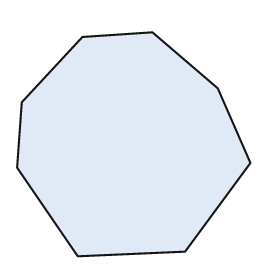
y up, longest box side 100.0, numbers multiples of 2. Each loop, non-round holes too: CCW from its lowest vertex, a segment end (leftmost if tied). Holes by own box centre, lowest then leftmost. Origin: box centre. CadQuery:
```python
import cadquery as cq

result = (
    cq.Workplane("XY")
    .moveTo(-24.0, -48.0)
    .lineTo(22.0, -46.0)
    .lineTo(50.0, -8.0)
    .lineTo(36.0, 24.0)
    .lineTo(8.0, 48.0)
    .lineTo(-22.0, 46.0)
    .lineTo(-48.0, 18.0)
    .lineTo(-50.0, -10.0)
    .close()
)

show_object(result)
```